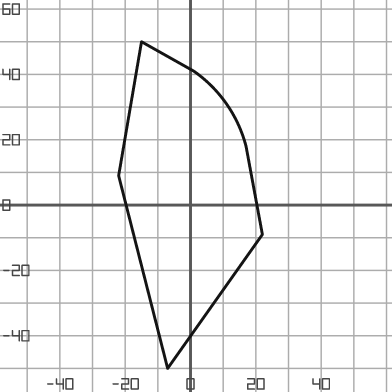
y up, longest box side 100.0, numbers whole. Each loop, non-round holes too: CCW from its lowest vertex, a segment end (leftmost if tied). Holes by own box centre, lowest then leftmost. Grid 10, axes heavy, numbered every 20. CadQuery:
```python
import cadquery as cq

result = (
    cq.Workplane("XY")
    .moveTo(-7.0, -50.0)
    .lineTo(22.0, -9.0)
    .lineTo(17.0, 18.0)
    .threePointArc((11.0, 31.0), (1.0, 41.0))
    .lineTo(-15.0, 50.0)
    .lineTo(-22.0, 9.0)
    .close()
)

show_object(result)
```